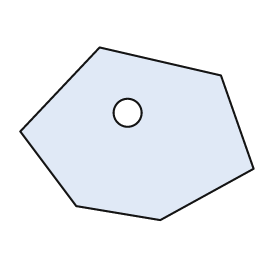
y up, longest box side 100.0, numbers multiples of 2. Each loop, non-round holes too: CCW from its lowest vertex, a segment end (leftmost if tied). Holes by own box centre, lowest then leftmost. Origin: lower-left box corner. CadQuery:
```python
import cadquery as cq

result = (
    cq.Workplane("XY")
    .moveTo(60.0, 0.0)
    .lineTo(100.0, 22.0)
    .lineTo(86.0, 62.0)
    .lineTo(34.0, 74.0)
    .lineTo(0.0, 38.0)
    .lineTo(24.0, 6.0)
    .close()
    .moveTo(46.0, 46.0)
    .circle(6.0)
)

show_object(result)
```